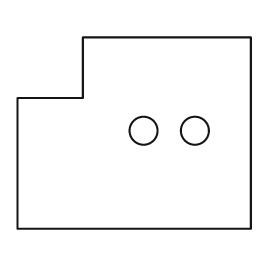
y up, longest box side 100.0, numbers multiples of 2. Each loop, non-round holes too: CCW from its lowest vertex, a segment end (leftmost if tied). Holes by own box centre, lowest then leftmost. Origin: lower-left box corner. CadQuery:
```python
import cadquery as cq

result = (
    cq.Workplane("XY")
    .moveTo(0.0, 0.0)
    .lineTo(100.0, 0.0)
    .lineTo(100.0, 82.0)
    .lineTo(28.0, 82.0)
    .lineTo(28.0, 56.0)
    .lineTo(0.0, 56.0)
    .close()
    .moveTo(54.0, 42.0)
    .circle(6.0)
    .moveTo(76.0, 42.0)
    .circle(6.0)
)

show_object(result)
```